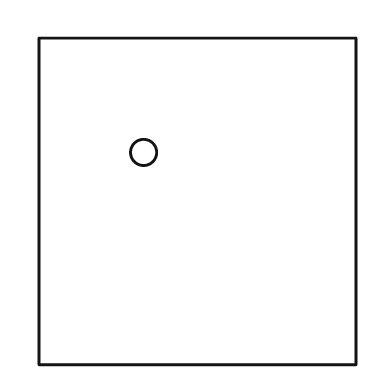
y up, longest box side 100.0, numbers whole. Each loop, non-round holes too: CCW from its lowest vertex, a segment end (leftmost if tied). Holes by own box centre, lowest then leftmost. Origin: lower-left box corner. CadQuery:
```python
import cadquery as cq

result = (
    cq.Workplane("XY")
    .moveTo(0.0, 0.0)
    .lineTo(97.0, 0.0)
    .lineTo(97.0, 100.0)
    .lineTo(0.0, 100.0)
    .close()
    .moveTo(32.0, 65.0)
    .circle(4.0)
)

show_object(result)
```